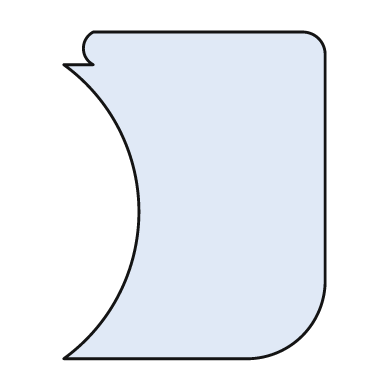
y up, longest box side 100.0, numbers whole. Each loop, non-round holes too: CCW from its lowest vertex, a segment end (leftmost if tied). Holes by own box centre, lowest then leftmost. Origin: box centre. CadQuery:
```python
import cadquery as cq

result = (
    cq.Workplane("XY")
    .moveTo(-40.0, -50.0)
    .lineTo(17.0, -50.0)
    .threePointArc((33.0, -43.0), (40.0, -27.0))
    .lineTo(40.0, 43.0)
    .threePointArc((38.0, 48.0), (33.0, 50.0))
    .lineTo(-31.0, 50.0)
    .threePointArc((-34.0, 45.0), (-31.0, 40.0))
    .lineTo(-40.0, 40.0)
    .threePointArc((-17.0, -5.0), (-40.0, -50.0))
    .close()
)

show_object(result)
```